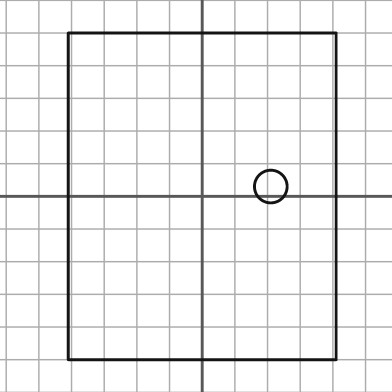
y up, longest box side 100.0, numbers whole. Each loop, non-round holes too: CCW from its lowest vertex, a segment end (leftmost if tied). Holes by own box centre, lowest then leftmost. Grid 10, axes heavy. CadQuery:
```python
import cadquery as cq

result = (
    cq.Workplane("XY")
    .moveTo(-41.0, -50.0)
    .lineTo(41.0, -50.0)
    .lineTo(41.0, 50.0)
    .lineTo(-41.0, 50.0)
    .close()
    .moveTo(21.0, 3.0)
    .circle(5.0)
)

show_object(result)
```